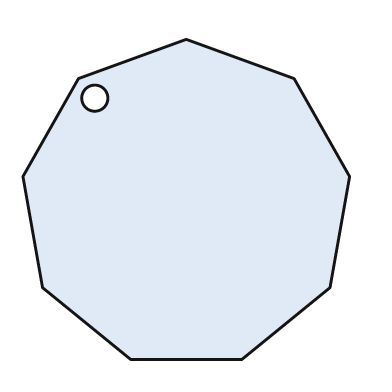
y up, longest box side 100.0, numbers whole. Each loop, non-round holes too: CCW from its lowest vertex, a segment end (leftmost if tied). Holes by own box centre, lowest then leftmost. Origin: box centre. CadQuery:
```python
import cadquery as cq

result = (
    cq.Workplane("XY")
    .moveTo(-17.0, -49.0)
    .lineTo(17.0, -49.0)
    .lineTo(44.0, -27.0)
    .lineTo(50.0, 7.0)
    .lineTo(33.0, 37.0)
    .lineTo(0.0, 49.0)
    .lineTo(-33.0, 37.0)
    .lineTo(-50.0, 7.0)
    .lineTo(-44.0, -27.0)
    .close()
    .moveTo(-28.0, 31.0)
    .circle(4.0)
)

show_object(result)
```